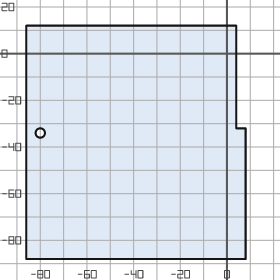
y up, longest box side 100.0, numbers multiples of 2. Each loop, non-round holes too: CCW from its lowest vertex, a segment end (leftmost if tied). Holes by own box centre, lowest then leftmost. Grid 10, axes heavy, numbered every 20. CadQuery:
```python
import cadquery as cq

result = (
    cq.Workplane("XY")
    .moveTo(-86.0, -88.0)
    .lineTo(8.0, -88.0)
    .lineTo(8.0, -32.0)
    .lineTo(4.0, -32.0)
    .lineTo(4.0, 12.0)
    .lineTo(-86.0, 12.0)
    .close()
    .moveTo(-80.0, -34.0)
    .circle(2.0)
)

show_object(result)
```